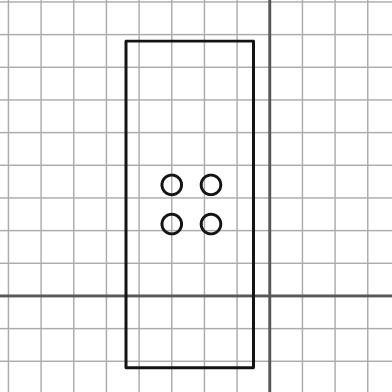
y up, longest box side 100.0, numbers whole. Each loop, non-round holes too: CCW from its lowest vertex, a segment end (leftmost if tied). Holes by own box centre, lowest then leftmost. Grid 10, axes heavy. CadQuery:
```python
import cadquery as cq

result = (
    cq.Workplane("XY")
    .moveTo(-44.0, -22.0)
    .lineTo(-5.0, -22.0)
    .lineTo(-5.0, 78.0)
    .lineTo(-44.0, 78.0)
    .close()
    .moveTo(-30.0, 22.0)
    .circle(3.0)
    .moveTo(-18.0, 22.0)
    .circle(3.0)
    .moveTo(-30.0, 34.0)
    .circle(3.0)
    .moveTo(-18.0, 34.0)
    .circle(3.0)
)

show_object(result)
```